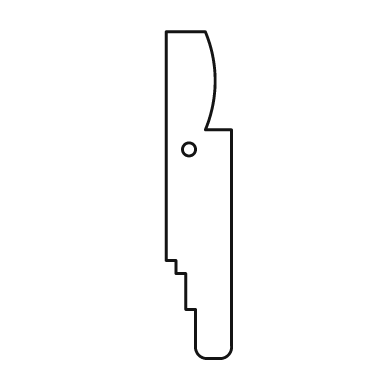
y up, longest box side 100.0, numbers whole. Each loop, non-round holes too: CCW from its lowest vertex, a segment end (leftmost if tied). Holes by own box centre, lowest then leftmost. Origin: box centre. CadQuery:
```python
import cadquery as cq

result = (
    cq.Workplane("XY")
    .moveTo(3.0, -50.0)
    .lineTo(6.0, -50.0)
    .threePointArc((9.0, -49.0), (10.0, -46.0))
    .lineTo(10.0, 20.0)
    .lineTo(2.0, 20.0)
    .threePointArc((5.0, 35.0), (2.0, 50.0))
    .lineTo(-10.0, 50.0)
    .lineTo(-10.0, -20.0)
    .lineTo(-7.0, -20.0)
    .lineTo(-7.0, -24.0)
    .lineTo(-4.0, -24.0)
    .lineTo(-4.0, -35.0)
    .lineTo(-1.0, -35.0)
    .lineTo(-1.0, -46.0)
    .threePointArc((0.0, -49.0), (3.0, -50.0))
    .close()
    .moveTo(-3.0, 14.0)
    .circle(2.0)
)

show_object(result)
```